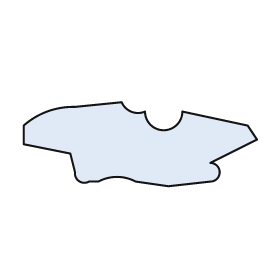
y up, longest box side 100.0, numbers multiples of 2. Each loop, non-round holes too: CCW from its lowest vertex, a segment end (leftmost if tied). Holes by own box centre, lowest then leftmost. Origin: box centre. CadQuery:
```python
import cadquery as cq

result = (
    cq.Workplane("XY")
    .moveTo(12.0, -18.0)
    .lineTo(30.0, -16.0)
    .threePointArc((34.0, -12.0), (30.0, -8.0))
    .lineTo(50.0, 2.0)
    .lineTo(46.0, 8.0)
    .lineTo(18.0, 14.0)
    .threePointArc((10.0, 6.0), (2.0, 14.0))
    .threePointArc((-4.0, 14.0), (-8.0, 18.0))
    .lineTo(-28.0, 16.0)
    .threePointArc((-40.0, 14.0), (-50.0, 8.0))
    .lineTo(-50.0, 0.0)
    .lineTo(-30.0, -4.0)
    .lineTo(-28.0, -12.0)
    .threePointArc((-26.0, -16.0), (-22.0, -16.0))
    .lineTo(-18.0, -16.0)
    .threePointArc((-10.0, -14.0), (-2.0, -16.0))
    .close()
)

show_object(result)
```